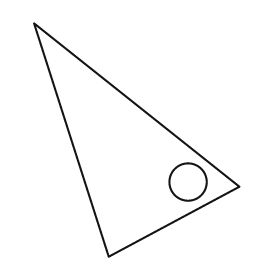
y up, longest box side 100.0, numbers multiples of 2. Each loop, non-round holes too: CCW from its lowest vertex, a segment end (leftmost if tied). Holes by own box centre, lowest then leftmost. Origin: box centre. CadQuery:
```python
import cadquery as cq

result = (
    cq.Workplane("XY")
    .moveTo(-12.0, -50.0)
    .lineTo(44.0, -20.0)
    .lineTo(-44.0, 50.0)
    .close()
    .moveTo(22.0, -18.0)
    .circle(8.0)
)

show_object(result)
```